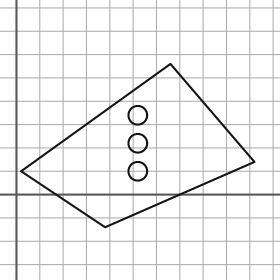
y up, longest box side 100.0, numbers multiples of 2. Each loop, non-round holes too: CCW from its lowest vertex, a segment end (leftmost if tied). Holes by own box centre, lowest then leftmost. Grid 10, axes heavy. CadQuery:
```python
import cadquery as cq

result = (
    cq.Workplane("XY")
    .moveTo(38.0, -14.0)
    .lineTo(102.0, 14.0)
    .lineTo(66.0, 56.0)
    .lineTo(2.0, 10.0)
    .close()
    .moveTo(52.0, 10.0)
    .circle(4.0)
    .moveTo(52.0, 22.0)
    .circle(4.0)
    .moveTo(52.0, 34.0)
    .circle(4.0)
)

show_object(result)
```